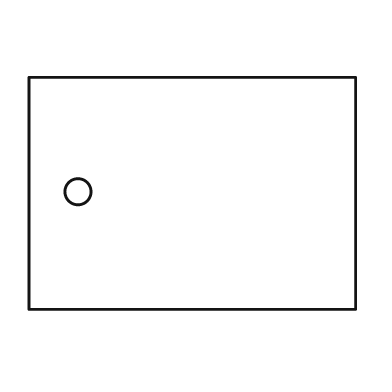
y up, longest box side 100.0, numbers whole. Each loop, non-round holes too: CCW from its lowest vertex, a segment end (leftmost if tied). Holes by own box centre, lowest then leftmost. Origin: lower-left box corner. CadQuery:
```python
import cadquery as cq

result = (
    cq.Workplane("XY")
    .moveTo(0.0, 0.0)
    .lineTo(100.0, 0.0)
    .lineTo(100.0, 71.0)
    .lineTo(0.0, 71.0)
    .close()
    .moveTo(15.0, 36.0)
    .circle(4.0)
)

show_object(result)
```